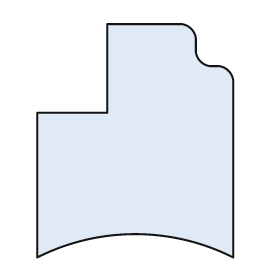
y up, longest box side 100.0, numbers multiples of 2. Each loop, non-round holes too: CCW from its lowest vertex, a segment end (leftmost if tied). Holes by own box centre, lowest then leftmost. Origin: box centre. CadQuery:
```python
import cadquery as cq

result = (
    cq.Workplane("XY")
    .moveTo(-42.0, -50.0)
    .threePointArc((0.0, -40.0), (42.0, -50.0))
    .lineTo(42.0, 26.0)
    .threePointArc((40.0, 30.0), (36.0, 32.0))
    .lineTo(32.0, 32.0)
    .threePointArc((28.0, 34.0), (26.0, 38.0))
    .lineTo(26.0, 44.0)
    .threePointArc((24.0, 48.0), (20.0, 50.0))
    .lineTo(-12.0, 50.0)
    .lineTo(-12.0, 12.0)
    .lineTo(-42.0, 12.0)
    .close()
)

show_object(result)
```